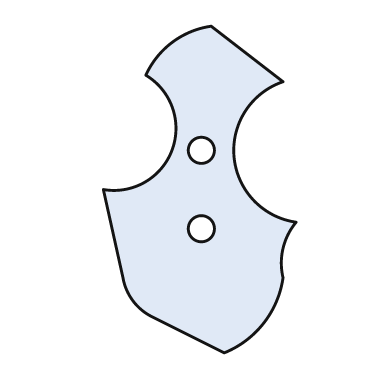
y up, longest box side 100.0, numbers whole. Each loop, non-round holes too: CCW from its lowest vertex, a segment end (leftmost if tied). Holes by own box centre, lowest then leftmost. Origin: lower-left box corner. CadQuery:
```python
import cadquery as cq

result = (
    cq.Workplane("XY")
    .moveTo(37.0, 0.0)
    .threePointArc((49.0, 9.0), (55.0, 23.0))
    .threePointArc((55.0, 32.0), (59.0, 40.0))
    .threePointArc((40.0, 60.0), (55.0, 83.0))
    .lineTo(33.0, 100.0)
    .threePointArc((21.0, 95.0), (13.0, 85.0))
    .threePointArc((21.0, 62.0), (0.0, 50.0))
    .lineTo(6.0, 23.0)
    .threePointArc((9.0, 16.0), (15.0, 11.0))
    .close()
    .moveTo(30.0, 38.0)
    .circle(4.0)
    .moveTo(30.0, 62.0)
    .circle(4.0)
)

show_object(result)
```